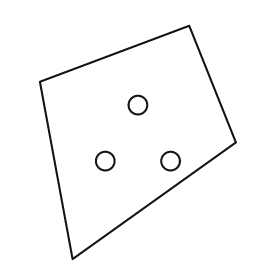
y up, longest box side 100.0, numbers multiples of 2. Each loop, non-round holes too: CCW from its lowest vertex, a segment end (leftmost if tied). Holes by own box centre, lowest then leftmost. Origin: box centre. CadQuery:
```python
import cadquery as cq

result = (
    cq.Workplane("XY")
    .moveTo(-28.0, -50.0)
    .lineTo(42.0, 0.0)
    .lineTo(22.0, 50.0)
    .lineTo(-42.0, 26.0)
    .close()
    .moveTo(-14.0, -8.0)
    .circle(4.0)
    .moveTo(14.0, -8.0)
    .circle(4.0)
    .moveTo(0.0, 16.0)
    .circle(4.0)
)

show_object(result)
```